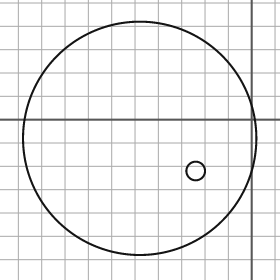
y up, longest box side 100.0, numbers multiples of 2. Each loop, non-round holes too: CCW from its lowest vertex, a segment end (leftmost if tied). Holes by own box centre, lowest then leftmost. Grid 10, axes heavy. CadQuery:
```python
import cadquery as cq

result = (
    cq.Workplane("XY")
    .moveTo(-48.0, -8.0)
    .circle(50.0)
    .moveTo(-24.0, -22.0)
    .circle(4.0)
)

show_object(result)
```